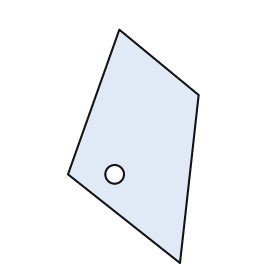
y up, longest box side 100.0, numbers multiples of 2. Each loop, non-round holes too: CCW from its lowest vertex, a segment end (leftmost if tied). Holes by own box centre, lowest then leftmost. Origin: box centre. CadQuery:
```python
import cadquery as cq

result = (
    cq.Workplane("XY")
    .moveTo(20.0, -50.0)
    .lineTo(28.0, 22.0)
    .lineTo(-6.0, 50.0)
    .lineTo(-28.0, -12.0)
    .close()
    .moveTo(-8.0, -12.0)
    .circle(4.0)
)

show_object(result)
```